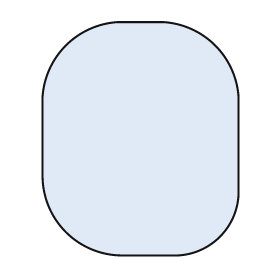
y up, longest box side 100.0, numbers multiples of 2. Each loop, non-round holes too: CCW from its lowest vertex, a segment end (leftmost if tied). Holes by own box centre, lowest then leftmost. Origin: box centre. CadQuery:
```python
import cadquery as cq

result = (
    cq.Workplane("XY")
    .moveTo(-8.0, -50.0)
    .lineTo(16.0, -50.0)
    .threePointArc((34.0, -42.0), (42.0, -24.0))
    .lineTo(42.0, 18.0)
    .threePointArc((32.0, 40.0), (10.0, 50.0))
    .lineTo(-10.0, 50.0)
    .threePointArc((-32.0, 40.0), (-42.0, 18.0))
    .lineTo(-42.0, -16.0)
    .threePointArc((-32.0, -40.0), (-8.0, -50.0))
    .close()
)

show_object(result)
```